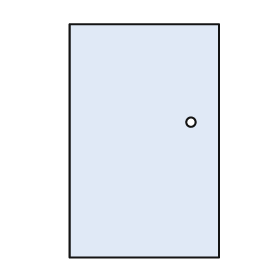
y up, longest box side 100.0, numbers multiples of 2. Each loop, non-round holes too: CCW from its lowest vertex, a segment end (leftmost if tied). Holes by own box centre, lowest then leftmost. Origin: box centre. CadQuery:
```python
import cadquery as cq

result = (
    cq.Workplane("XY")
    .moveTo(-32.0, -50.0)
    .lineTo(32.0, -50.0)
    .lineTo(32.0, 50.0)
    .lineTo(-32.0, 50.0)
    .close()
    .moveTo(20.0, 8.0)
    .circle(2.0)
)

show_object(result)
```